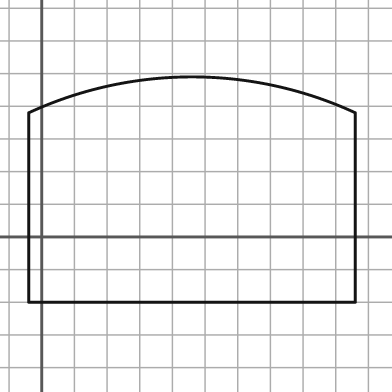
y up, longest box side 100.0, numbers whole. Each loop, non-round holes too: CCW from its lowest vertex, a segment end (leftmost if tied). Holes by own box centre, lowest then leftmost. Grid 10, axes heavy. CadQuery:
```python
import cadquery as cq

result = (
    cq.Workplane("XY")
    .moveTo(-4.0, -20.0)
    .lineTo(96.0, -20.0)
    .lineTo(96.0, 38.0)
    .threePointArc((46.0, 49.0), (-4.0, 38.0))
    .close()
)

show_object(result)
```